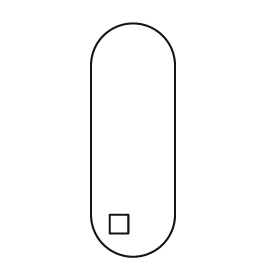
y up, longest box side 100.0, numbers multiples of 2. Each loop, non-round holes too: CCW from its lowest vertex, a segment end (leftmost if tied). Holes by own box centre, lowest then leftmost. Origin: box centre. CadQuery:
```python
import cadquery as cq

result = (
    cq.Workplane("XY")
    .moveTo(-18.0, -32.0)
    .threePointArc((0.0, -50.0), (18.0, -32.0))
    .lineTo(18.0, 32.0)
    .threePointArc((0.0, 50.0), (-18.0, 32.0))
    .close()
    .moveTo(-10.0, -40.0)
    .lineTo(-2.0, -40.0)
    .lineTo(-2.0, -32.0)
    .lineTo(-10.0, -32.0)
    .close()
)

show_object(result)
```